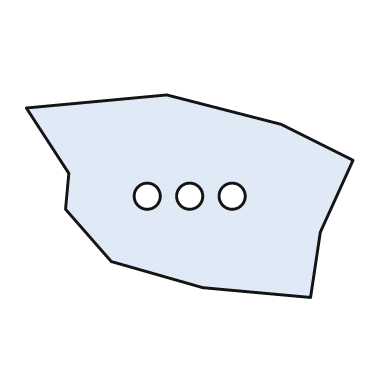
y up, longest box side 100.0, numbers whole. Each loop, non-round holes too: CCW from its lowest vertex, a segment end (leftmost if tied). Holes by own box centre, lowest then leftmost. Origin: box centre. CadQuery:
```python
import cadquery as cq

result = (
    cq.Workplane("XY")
    .moveTo(37.0, -31.0)
    .lineTo(40.0, -11.0)
    .lineTo(50.0, 11.0)
    .lineTo(28.0, 22.0)
    .lineTo(-7.0, 31.0)
    .lineTo(-50.0, 27.0)
    .lineTo(-37.0, 7.0)
    .lineTo(-38.0, -4.0)
    .lineTo(-24.0, -20.0)
    .lineTo(4.0, -28.0)
    .close()
    .moveTo(-13.0, 0.0)
    .circle(4.0)
    .moveTo(0.0, 0.0)
    .circle(4.0)
    .moveTo(13.0, 0.0)
    .circle(4.0)
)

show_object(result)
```